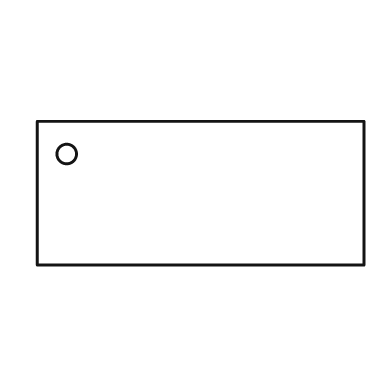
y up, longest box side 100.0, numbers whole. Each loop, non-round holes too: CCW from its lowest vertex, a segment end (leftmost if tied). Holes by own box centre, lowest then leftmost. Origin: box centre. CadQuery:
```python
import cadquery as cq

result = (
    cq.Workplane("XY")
    .moveTo(-50.0, -22.0)
    .lineTo(50.0, -22.0)
    .lineTo(50.0, 22.0)
    .lineTo(-50.0, 22.0)
    .close()
    .moveTo(-41.0, 12.0)
    .circle(3.0)
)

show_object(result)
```